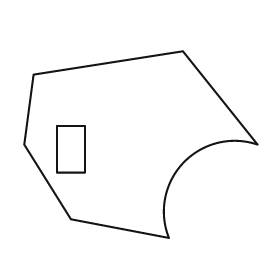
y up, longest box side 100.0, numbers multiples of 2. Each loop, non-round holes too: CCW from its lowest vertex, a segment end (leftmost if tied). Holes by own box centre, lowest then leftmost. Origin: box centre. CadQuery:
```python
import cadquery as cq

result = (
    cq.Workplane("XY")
    .moveTo(12.0, -40.0)
    .threePointArc((18.0, -8.0), (50.0, 0.0))
    .lineTo(18.0, 40.0)
    .lineTo(-46.0, 30.0)
    .lineTo(-50.0, 0.0)
    .lineTo(-30.0, -32.0)
    .close()
    .moveTo(-36.0, -12.0)
    .lineTo(-24.0, -12.0)
    .lineTo(-24.0, 8.0)
    .lineTo(-36.0, 8.0)
    .close()
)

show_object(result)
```